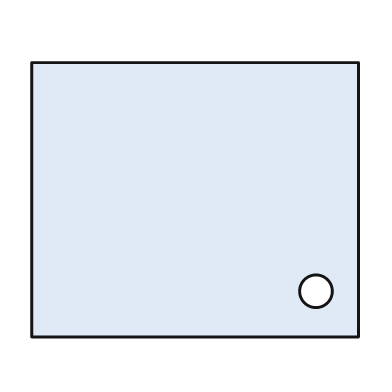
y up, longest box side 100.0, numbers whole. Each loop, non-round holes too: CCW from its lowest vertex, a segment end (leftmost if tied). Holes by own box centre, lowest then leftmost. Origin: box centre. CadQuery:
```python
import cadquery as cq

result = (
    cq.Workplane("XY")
    .moveTo(-50.0, -42.0)
    .lineTo(50.0, -42.0)
    .lineTo(50.0, 42.0)
    .lineTo(-50.0, 42.0)
    .close()
    .moveTo(37.0, -28.0)
    .circle(5.0)
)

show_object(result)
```